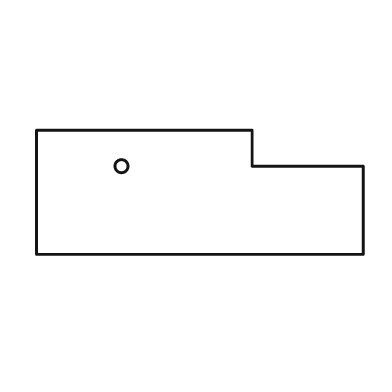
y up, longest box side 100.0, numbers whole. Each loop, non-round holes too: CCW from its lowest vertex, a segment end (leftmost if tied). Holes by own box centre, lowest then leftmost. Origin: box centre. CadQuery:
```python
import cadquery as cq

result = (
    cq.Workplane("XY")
    .moveTo(-50.0, -19.0)
    .lineTo(50.0, -19.0)
    .lineTo(50.0, 8.0)
    .lineTo(16.0, 8.0)
    .lineTo(16.0, 19.0)
    .lineTo(-50.0, 19.0)
    .close()
    .moveTo(-24.0, 8.0)
    .circle(2.0)
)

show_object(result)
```